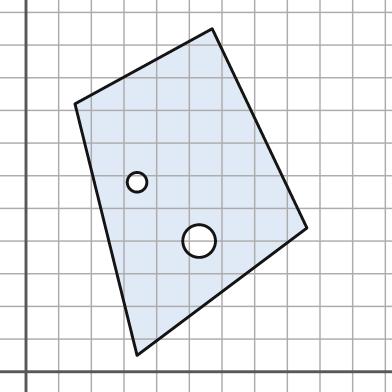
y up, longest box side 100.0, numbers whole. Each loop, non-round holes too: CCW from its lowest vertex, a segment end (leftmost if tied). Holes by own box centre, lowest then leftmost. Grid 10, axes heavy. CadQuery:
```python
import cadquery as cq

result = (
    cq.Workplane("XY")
    .moveTo(34.0, 5.0)
    .lineTo(86.0, 44.0)
    .lineTo(57.0, 105.0)
    .lineTo(15.0, 82.0)
    .close()
    .moveTo(53.0, 40.0)
    .circle(5.0)
    .moveTo(34.0, 58.0)
    .circle(3.0)
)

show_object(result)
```